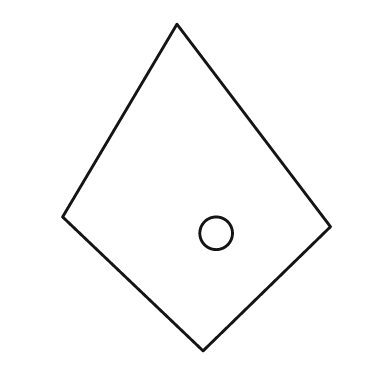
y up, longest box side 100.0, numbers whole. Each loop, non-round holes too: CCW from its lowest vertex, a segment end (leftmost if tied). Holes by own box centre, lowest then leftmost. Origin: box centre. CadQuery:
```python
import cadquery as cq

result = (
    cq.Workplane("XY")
    .moveTo(2.0, -50.0)
    .lineTo(41.0, -12.0)
    .lineTo(-6.0, 50.0)
    .lineTo(-41.0, -9.0)
    .close()
    .moveTo(6.0, -14.0)
    .circle(5.0)
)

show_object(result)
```